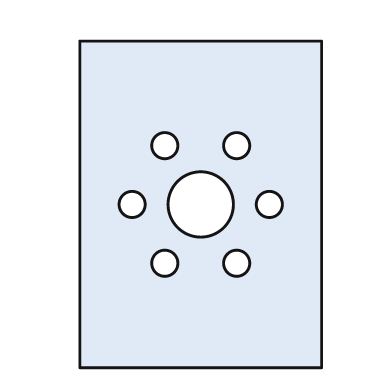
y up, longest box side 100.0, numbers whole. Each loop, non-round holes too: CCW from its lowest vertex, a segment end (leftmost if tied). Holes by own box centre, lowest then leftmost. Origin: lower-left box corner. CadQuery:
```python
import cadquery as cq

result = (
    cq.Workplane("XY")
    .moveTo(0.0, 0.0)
    .lineTo(74.0, 0.0)
    .lineTo(74.0, 100.0)
    .lineTo(0.0, 100.0)
    .close()
    .moveTo(26.0, 32.0)
    .circle(4.0)
    .moveTo(48.0, 32.0)
    .circle(4.0)
    .moveTo(16.0, 50.0)
    .circle(4.0)
    .moveTo(37.0, 50.0)
    .circle(10.0)
    .moveTo(58.0, 50.0)
    .circle(4.0)
    .moveTo(26.0, 68.0)
    .circle(4.0)
    .moveTo(48.0, 68.0)
    .circle(4.0)
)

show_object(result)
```